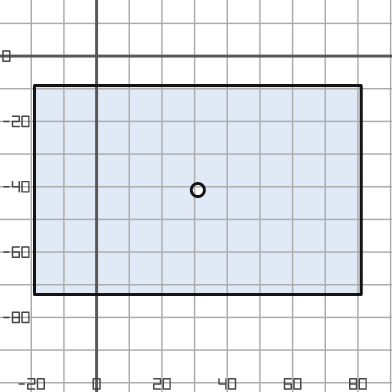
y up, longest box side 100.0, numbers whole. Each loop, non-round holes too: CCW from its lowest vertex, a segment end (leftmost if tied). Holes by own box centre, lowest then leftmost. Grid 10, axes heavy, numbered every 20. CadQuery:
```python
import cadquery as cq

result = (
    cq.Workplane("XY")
    .moveTo(-19.0, -73.0)
    .lineTo(81.0, -73.0)
    .lineTo(81.0, -9.0)
    .lineTo(-19.0, -9.0)
    .close()
    .moveTo(31.0, -41.0)
    .circle(2.0)
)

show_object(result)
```